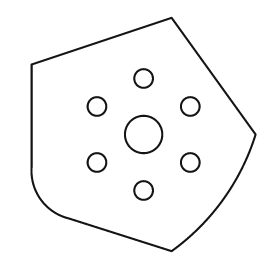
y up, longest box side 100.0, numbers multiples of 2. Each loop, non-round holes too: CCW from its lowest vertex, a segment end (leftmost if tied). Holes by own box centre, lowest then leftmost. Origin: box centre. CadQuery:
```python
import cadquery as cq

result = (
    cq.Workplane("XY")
    .moveTo(12.0, -50.0)
    .threePointArc((34.0, -28.0), (48.0, 0.0))
    .lineTo(12.0, 50.0)
    .lineTo(-48.0, 30.0)
    .lineTo(-48.0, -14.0)
    .threePointArc((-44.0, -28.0), (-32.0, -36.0))
    .close()
    .moveTo(0.0, -24.0)
    .circle(4.0)
    .moveTo(-20.0, -12.0)
    .circle(4.0)
    .moveTo(20.0, -12.0)
    .circle(4.0)
    .moveTo(0.0, 0.0)
    .circle(8.0)
    .moveTo(-20.0, 12.0)
    .circle(4.0)
    .moveTo(20.0, 12.0)
    .circle(4.0)
    .moveTo(0.0, 24.0)
    .circle(4.0)
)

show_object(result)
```